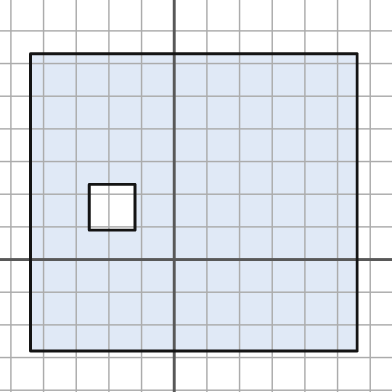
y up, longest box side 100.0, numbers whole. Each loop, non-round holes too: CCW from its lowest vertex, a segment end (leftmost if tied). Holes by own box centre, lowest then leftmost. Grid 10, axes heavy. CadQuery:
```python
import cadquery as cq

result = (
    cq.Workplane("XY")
    .moveTo(-44.0, -28.0)
    .lineTo(56.0, -28.0)
    .lineTo(56.0, 63.0)
    .lineTo(-44.0, 63.0)
    .close()
    .moveTo(-26.0, 9.0)
    .lineTo(-12.0, 9.0)
    .lineTo(-12.0, 23.0)
    .lineTo(-26.0, 23.0)
    .close()
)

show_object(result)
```